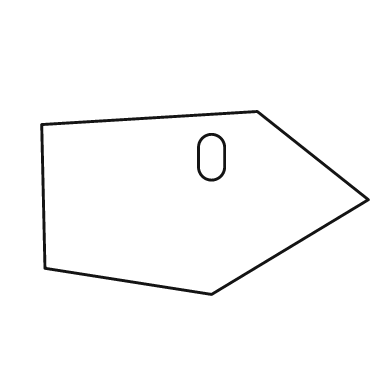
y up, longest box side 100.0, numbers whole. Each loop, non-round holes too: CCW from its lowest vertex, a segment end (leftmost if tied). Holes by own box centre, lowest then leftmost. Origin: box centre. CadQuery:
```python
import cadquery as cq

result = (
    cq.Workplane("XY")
    .moveTo(2.0, -28.0)
    .lineTo(50.0, 1.0)
    .lineTo(16.0, 28.0)
    .lineTo(-50.0, 24.0)
    .lineTo(-49.0, -20.0)
    .close()
    .moveTo(-2.0, 11.0)
    .threePointArc((2.0, 7.0), (6.0, 11.0))
    .lineTo(6.0, 17.0)
    .threePointArc((2.0, 21.0), (-2.0, 17.0))
    .close()
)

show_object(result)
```